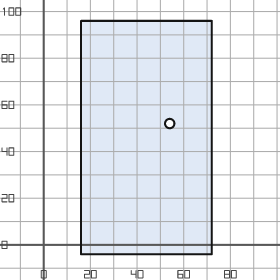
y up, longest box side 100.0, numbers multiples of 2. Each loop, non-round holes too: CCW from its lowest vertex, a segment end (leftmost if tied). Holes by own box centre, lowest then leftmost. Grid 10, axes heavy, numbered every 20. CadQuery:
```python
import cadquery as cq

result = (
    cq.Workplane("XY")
    .moveTo(16.0, -4.0)
    .lineTo(72.0, -4.0)
    .lineTo(72.0, 96.0)
    .lineTo(16.0, 96.0)
    .close()
    .moveTo(54.0, 52.0)
    .circle(2.0)
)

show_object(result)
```